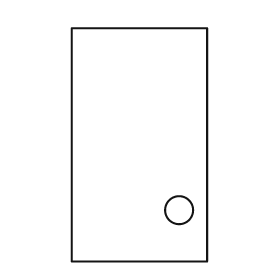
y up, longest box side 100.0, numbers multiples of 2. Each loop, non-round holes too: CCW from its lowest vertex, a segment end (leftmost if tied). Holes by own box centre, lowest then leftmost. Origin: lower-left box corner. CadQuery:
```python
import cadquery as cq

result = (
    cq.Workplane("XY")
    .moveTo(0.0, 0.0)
    .lineTo(58.0, 0.0)
    .lineTo(58.0, 100.0)
    .lineTo(0.0, 100.0)
    .close()
    .moveTo(46.0, 22.0)
    .circle(6.0)
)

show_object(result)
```